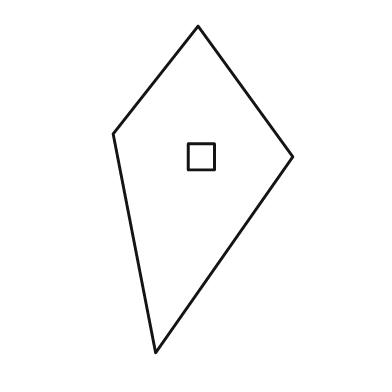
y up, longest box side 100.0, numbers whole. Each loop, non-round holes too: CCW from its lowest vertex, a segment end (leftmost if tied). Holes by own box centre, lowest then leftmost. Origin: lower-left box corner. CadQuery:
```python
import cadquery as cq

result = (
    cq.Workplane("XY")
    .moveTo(13.0, 0.0)
    .lineTo(55.0, 60.0)
    .lineTo(26.0, 100.0)
    .lineTo(0.0, 67.0)
    .close()
    .moveTo(23.0, 56.0)
    .lineTo(31.0, 56.0)
    .lineTo(31.0, 64.0)
    .lineTo(23.0, 64.0)
    .close()
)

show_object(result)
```